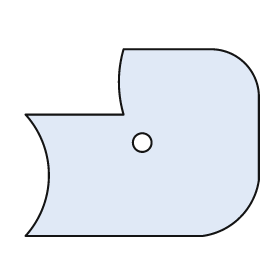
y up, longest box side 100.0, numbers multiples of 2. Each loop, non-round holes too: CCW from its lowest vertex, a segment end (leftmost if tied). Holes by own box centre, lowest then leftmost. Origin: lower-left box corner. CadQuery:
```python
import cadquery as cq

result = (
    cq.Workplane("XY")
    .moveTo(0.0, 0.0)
    .lineTo(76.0, 0.0)
    .threePointArc((92.0, 8.0), (100.0, 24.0))
    .lineTo(100.0, 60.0)
    .threePointArc((94.0, 74.0), (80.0, 80.0))
    .lineTo(42.0, 80.0)
    .threePointArc((40.0, 66.0), (42.0, 52.0))
    .lineTo(0.0, 52.0)
    .threePointArc((10.0, 26.0), (0.0, 0.0))
    .close()
    .moveTo(50.0, 40.0)
    .circle(4.0)
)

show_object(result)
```